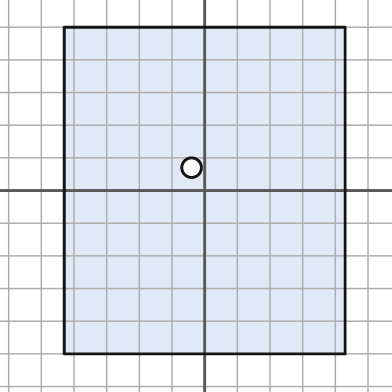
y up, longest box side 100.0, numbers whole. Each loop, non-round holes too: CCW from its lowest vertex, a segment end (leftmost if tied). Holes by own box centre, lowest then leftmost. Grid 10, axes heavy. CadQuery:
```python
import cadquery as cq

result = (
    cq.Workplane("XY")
    .moveTo(-43.0, -50.0)
    .lineTo(43.0, -50.0)
    .lineTo(43.0, 50.0)
    .lineTo(-43.0, 50.0)
    .close()
    .moveTo(-4.0, 7.0)
    .circle(3.0)
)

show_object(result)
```